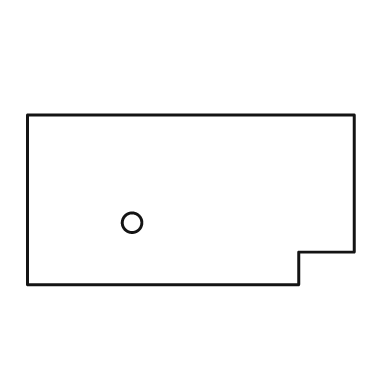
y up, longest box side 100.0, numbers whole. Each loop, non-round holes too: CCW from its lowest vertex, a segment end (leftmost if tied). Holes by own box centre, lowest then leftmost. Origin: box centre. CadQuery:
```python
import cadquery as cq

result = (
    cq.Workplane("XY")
    .moveTo(-50.0, -26.0)
    .lineTo(33.0, -26.0)
    .lineTo(33.0, -16.0)
    .lineTo(50.0, -16.0)
    .lineTo(50.0, 26.0)
    .lineTo(-50.0, 26.0)
    .close()
    .moveTo(-18.0, -7.0)
    .circle(3.0)
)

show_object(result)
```